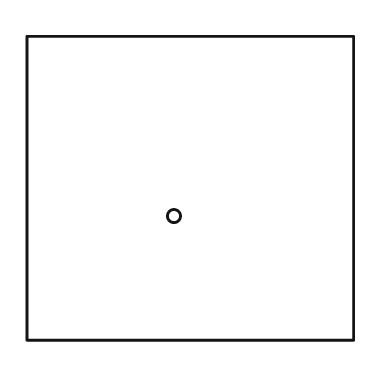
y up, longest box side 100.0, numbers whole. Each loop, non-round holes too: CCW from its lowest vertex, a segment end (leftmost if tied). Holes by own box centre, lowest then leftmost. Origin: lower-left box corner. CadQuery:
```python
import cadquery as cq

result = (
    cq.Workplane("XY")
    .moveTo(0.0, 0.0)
    .lineTo(100.0, 0.0)
    .lineTo(100.0, 93.0)
    .lineTo(0.0, 93.0)
    .close()
    .moveTo(45.0, 38.0)
    .circle(2.0)
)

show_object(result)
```